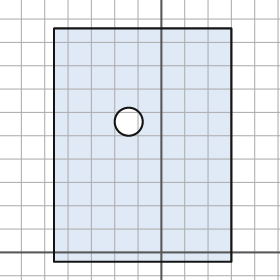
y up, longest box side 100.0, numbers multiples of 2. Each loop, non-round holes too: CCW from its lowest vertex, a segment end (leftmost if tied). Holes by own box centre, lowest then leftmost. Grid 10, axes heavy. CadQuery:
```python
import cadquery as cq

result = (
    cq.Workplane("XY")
    .moveTo(-46.0, -4.0)
    .lineTo(30.0, -4.0)
    .lineTo(30.0, 96.0)
    .lineTo(-46.0, 96.0)
    .close()
    .moveTo(-14.0, 56.0)
    .circle(6.0)
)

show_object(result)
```